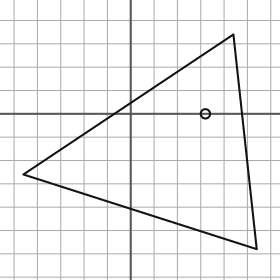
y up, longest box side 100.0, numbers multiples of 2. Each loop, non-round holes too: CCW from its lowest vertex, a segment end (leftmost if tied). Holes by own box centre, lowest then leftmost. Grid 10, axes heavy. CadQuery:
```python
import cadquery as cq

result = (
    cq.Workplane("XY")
    .moveTo(54.0, -58.0)
    .lineTo(44.0, 34.0)
    .lineTo(-46.0, -26.0)
    .close()
    .moveTo(32.0, 0.0)
    .circle(2.0)
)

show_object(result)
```